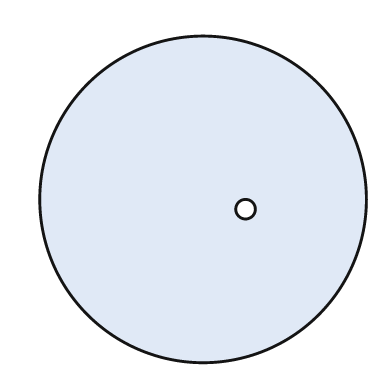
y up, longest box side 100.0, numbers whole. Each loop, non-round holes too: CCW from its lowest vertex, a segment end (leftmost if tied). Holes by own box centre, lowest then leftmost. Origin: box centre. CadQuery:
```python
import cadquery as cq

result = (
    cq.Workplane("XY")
    .moveTo(0.0, 0.0)
    .circle(50.0)
    .moveTo(13.0, -3.0)
    .circle(3.0)
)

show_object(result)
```